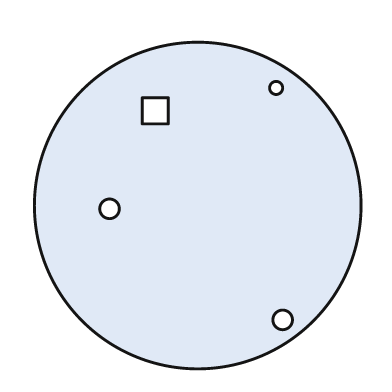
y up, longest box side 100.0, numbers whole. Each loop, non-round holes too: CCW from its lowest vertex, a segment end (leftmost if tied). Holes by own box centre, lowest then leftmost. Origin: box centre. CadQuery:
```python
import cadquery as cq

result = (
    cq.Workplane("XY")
    .moveTo(0.0, 0.0)
    .circle(50.0)
    .moveTo(26.0, -35.0)
    .circle(3.0)
    .moveTo(-27.0, -1.0)
    .circle(3.0)
    .moveTo(-17.0, 25.0)
    .lineTo(-9.0, 25.0)
    .lineTo(-9.0, 33.0)
    .lineTo(-17.0, 33.0)
    .close()
    .moveTo(24.0, 36.0)
    .circle(2.0)
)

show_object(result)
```